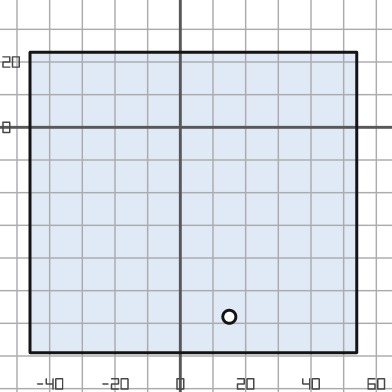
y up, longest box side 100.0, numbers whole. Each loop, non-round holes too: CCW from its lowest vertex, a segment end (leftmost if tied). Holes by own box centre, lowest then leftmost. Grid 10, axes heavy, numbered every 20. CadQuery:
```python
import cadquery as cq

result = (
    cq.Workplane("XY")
    .moveTo(-46.0, -69.0)
    .lineTo(54.0, -69.0)
    .lineTo(54.0, 23.0)
    .lineTo(-46.0, 23.0)
    .close()
    .moveTo(15.0, -58.0)
    .circle(2.0)
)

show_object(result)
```